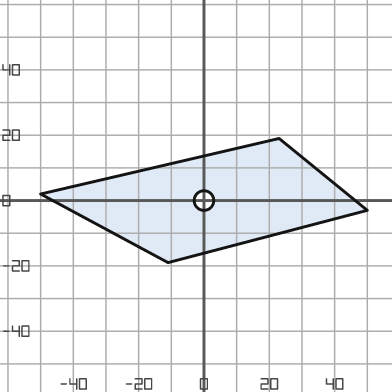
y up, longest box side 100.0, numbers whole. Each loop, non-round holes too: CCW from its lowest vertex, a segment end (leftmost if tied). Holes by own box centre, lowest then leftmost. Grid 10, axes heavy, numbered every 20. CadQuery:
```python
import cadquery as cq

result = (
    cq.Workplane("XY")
    .moveTo(-11.0, -19.0)
    .lineTo(50.0, -3.0)
    .lineTo(23.0, 19.0)
    .lineTo(-50.0, 2.0)
    .close()
    .moveTo(0.0, 0.0)
    .circle(3.0)
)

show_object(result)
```